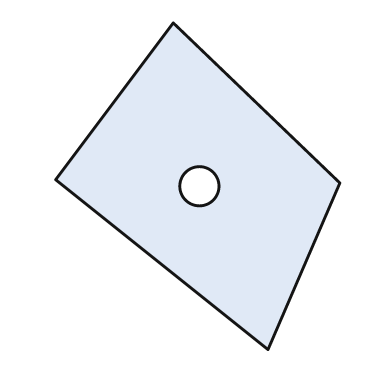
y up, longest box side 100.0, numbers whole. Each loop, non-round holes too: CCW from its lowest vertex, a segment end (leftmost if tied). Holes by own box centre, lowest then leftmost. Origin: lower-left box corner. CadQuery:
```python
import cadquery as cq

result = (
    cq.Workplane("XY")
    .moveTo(65.0, 0.0)
    .lineTo(87.0, 51.0)
    .lineTo(36.0, 100.0)
    .lineTo(0.0, 52.0)
    .close()
    .moveTo(44.0, 50.0)
    .circle(6.0)
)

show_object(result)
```